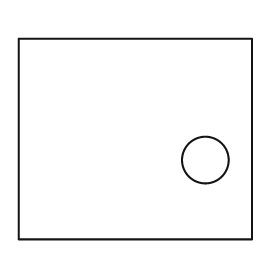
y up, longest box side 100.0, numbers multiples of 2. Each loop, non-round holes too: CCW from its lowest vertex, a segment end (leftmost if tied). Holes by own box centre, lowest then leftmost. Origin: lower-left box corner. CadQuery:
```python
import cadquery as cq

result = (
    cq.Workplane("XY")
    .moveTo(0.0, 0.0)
    .lineTo(100.0, 0.0)
    .lineTo(100.0, 86.0)
    .lineTo(0.0, 86.0)
    .close()
    .moveTo(80.0, 34.0)
    .circle(10.0)
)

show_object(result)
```